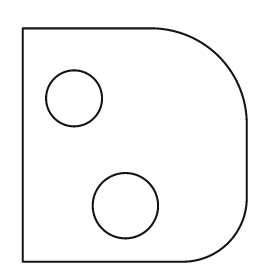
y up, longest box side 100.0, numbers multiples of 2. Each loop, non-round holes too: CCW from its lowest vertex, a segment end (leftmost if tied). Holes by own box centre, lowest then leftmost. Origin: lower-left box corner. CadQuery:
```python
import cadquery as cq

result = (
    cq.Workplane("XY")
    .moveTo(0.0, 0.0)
    .lineTo(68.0, 0.0)
    .threePointArc((88.0, 8.0), (96.0, 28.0))
    .lineTo(96.0, 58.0)
    .threePointArc((84.0, 88.0), (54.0, 100.0))
    .lineTo(0.0, 100.0)
    .close()
    .moveTo(44.0, 24.0)
    .circle(14.0)
    .moveTo(22.0, 70.0)
    .circle(12.0)
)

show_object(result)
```